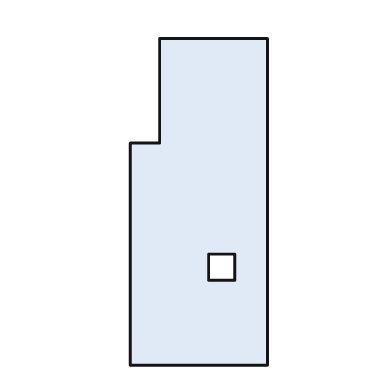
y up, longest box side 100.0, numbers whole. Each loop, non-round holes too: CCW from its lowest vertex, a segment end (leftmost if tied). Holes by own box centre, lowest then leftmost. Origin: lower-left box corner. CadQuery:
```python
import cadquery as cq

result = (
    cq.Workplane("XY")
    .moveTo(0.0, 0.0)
    .lineTo(42.0, 0.0)
    .lineTo(42.0, 100.0)
    .lineTo(9.0, 100.0)
    .lineTo(9.0, 68.0)
    .lineTo(0.0, 68.0)
    .close()
    .moveTo(24.0, 26.0)
    .lineTo(32.0, 26.0)
    .lineTo(32.0, 34.0)
    .lineTo(24.0, 34.0)
    .close()
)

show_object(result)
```